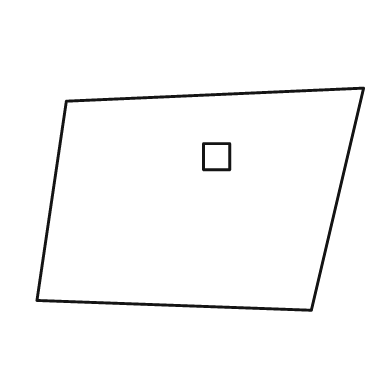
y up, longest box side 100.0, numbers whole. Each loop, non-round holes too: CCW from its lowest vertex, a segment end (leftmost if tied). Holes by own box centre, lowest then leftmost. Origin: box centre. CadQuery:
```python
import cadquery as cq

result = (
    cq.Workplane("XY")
    .moveTo(34.0, -34.0)
    .lineTo(50.0, 34.0)
    .lineTo(-41.0, 30.0)
    .lineTo(-50.0, -31.0)
    .close()
    .moveTo(1.0, 9.0)
    .lineTo(9.0, 9.0)
    .lineTo(9.0, 17.0)
    .lineTo(1.0, 17.0)
    .close()
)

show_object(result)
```